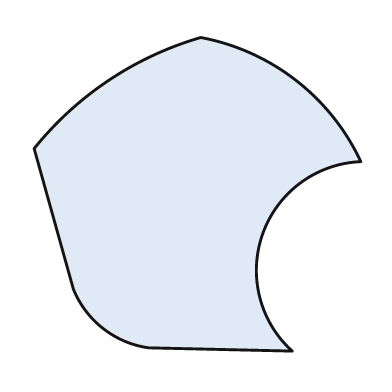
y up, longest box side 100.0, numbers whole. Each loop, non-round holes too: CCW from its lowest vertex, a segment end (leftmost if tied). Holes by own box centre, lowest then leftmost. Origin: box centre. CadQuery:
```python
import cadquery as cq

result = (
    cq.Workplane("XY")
    .moveTo(29.0, -48.0)
    .threePointArc((20.0, -12.0), (50.0, 10.0))
    .threePointArc((30.0, 35.0), (1.0, 48.0))
    .threePointArc((-27.0, 35.0), (-50.0, 14.0))
    .lineTo(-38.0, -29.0)
    .threePointArc((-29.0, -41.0), (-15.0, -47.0))
    .close()
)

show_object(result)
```